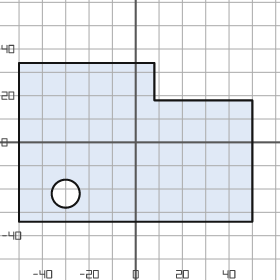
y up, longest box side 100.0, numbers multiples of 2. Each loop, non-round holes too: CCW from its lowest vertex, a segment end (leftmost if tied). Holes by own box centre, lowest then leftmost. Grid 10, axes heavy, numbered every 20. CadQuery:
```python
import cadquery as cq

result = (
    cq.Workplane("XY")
    .moveTo(-50.0, -34.0)
    .lineTo(50.0, -34.0)
    .lineTo(50.0, 18.0)
    .lineTo(8.0, 18.0)
    .lineTo(8.0, 34.0)
    .lineTo(-50.0, 34.0)
    .close()
    .moveTo(-30.0, -22.0)
    .circle(6.0)
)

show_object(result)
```